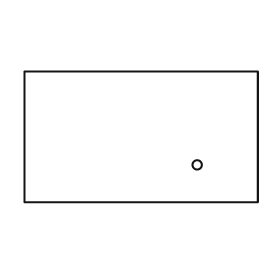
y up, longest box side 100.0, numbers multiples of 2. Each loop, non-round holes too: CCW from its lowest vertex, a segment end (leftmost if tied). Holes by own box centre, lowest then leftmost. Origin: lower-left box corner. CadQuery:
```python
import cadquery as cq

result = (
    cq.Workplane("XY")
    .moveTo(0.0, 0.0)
    .lineTo(100.0, 0.0)
    .lineTo(100.0, 56.0)
    .lineTo(0.0, 56.0)
    .close()
    .moveTo(74.0, 16.0)
    .circle(2.0)
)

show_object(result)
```